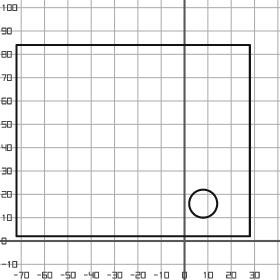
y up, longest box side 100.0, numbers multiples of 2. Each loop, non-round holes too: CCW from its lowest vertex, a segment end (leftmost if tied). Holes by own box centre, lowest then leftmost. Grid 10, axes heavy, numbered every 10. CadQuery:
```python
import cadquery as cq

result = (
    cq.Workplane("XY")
    .moveTo(-72.0, 2.0)
    .lineTo(28.0, 2.0)
    .lineTo(28.0, 84.0)
    .lineTo(-72.0, 84.0)
    .close()
    .moveTo(8.0, 16.0)
    .circle(6.0)
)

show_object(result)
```